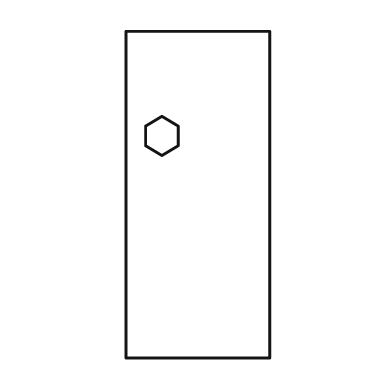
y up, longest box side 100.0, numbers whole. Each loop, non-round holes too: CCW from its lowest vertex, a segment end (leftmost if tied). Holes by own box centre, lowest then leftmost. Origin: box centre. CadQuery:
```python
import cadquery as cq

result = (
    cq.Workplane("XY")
    .moveTo(-22.0, -50.0)
    .lineTo(22.0, -50.0)
    .lineTo(22.0, 50.0)
    .lineTo(-22.0, 50.0)
    .close()
    .moveTo(-11.0, 12.0)
    .lineTo(-6.0, 15.0)
    .lineTo(-6.0, 21.0)
    .lineTo(-11.0, 24.0)
    .lineTo(-16.0, 21.0)
    .lineTo(-16.0, 15.0)
    .close()
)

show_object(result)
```